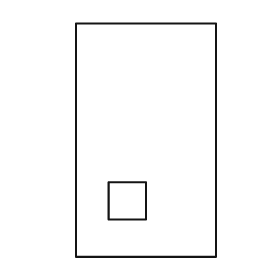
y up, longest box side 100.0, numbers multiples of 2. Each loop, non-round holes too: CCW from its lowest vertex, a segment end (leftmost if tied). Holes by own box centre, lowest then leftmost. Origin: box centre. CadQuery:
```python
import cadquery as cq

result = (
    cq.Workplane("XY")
    .moveTo(-30.0, -50.0)
    .lineTo(30.0, -50.0)
    .lineTo(30.0, 50.0)
    .lineTo(-30.0, 50.0)
    .close()
    .moveTo(-16.0, -34.0)
    .lineTo(0.0, -34.0)
    .lineTo(0.0, -18.0)
    .lineTo(-16.0, -18.0)
    .close()
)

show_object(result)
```